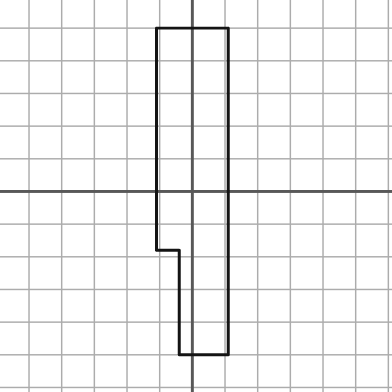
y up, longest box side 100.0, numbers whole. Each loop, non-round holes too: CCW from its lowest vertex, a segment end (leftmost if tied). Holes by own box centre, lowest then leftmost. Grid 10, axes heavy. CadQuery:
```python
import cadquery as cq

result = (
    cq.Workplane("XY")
    .moveTo(-4.0, -50.0)
    .lineTo(11.0, -50.0)
    .lineTo(11.0, 50.0)
    .lineTo(-11.0, 50.0)
    .lineTo(-11.0, -18.0)
    .lineTo(-4.0, -18.0)
    .close()
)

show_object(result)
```